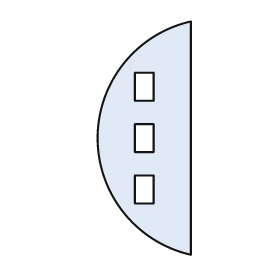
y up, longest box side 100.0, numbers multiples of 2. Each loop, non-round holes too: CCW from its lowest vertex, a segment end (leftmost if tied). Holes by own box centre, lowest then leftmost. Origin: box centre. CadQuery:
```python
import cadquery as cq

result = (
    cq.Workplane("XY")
    .moveTo(20.0, -50.0)
    .lineTo(20.0, 50.0)
    .threePointArc((-20.0, 0.0), (20.0, -50.0))
    .close()
    .moveTo(-4.0, -28.0)
    .lineTo(4.0, -28.0)
    .lineTo(4.0, -16.0)
    .lineTo(-4.0, -16.0)
    .close()
    .moveTo(-4.0, -6.0)
    .lineTo(4.0, -6.0)
    .lineTo(4.0, 6.0)
    .lineTo(-4.0, 6.0)
    .close()
    .moveTo(-4.0, 16.0)
    .lineTo(4.0, 16.0)
    .lineTo(4.0, 28.0)
    .lineTo(-4.0, 28.0)
    .close()
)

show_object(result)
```